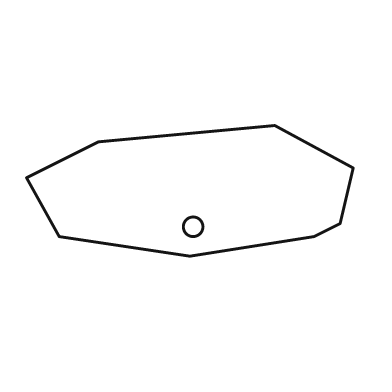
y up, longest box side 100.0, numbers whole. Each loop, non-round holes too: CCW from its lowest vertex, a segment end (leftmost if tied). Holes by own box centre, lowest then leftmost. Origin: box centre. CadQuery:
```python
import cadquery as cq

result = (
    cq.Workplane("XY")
    .moveTo(0.0, -20.0)
    .lineTo(38.0, -14.0)
    .lineTo(46.0, -10.0)
    .lineTo(50.0, 7.0)
    .lineTo(26.0, 20.0)
    .lineTo(-28.0, 15.0)
    .lineTo(-50.0, 4.0)
    .lineTo(-40.0, -14.0)
    .close()
    .moveTo(1.0, -11.0)
    .circle(3.0)
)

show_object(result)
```